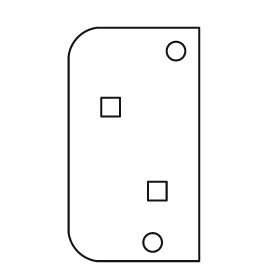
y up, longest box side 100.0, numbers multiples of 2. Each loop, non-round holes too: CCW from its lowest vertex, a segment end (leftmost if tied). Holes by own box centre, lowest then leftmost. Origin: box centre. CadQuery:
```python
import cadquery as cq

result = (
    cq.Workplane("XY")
    .moveTo(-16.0, -50.0)
    .lineTo(28.0, -50.0)
    .lineTo(28.0, 50.0)
    .lineTo(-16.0, 50.0)
    .threePointArc((-24.0, 46.0), (-28.0, 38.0))
    .lineTo(-28.0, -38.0)
    .threePointArc((-24.0, -46.0), (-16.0, -50.0))
    .close()
    .moveTo(8.0, -42.0)
    .circle(4.0)
    .moveTo(6.0, -24.0)
    .lineTo(14.0, -24.0)
    .lineTo(14.0, -16.0)
    .lineTo(6.0, -16.0)
    .close()
    .moveTo(-14.0, 12.0)
    .lineTo(-6.0, 12.0)
    .lineTo(-6.0, 20.0)
    .lineTo(-14.0, 20.0)
    .close()
    .moveTo(18.0, 40.0)
    .circle(4.0)
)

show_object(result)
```